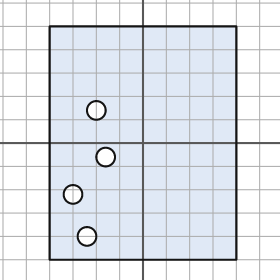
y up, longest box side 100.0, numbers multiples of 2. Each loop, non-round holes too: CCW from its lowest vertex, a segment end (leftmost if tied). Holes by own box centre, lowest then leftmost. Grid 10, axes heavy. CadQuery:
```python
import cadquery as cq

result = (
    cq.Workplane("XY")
    .moveTo(-40.0, -50.0)
    .lineTo(40.0, -50.0)
    .lineTo(40.0, 50.0)
    .lineTo(-40.0, 50.0)
    .close()
    .moveTo(-24.0, -40.0)
    .circle(4.0)
    .moveTo(-30.0, -22.0)
    .circle(4.0)
    .moveTo(-16.0, -6.0)
    .circle(4.0)
    .moveTo(-20.0, 14.0)
    .circle(4.0)
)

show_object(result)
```